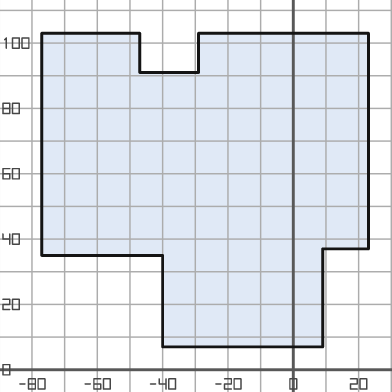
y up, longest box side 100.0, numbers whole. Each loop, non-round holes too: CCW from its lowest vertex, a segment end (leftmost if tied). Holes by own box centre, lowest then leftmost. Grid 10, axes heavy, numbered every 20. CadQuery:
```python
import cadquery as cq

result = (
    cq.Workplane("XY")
    .moveTo(-40.0, 7.0)
    .lineTo(9.0, 7.0)
    .lineTo(9.0, 37.0)
    .lineTo(23.0, 37.0)
    .lineTo(23.0, 103.0)
    .lineTo(-29.0, 103.0)
    .lineTo(-29.0, 91.0)
    .lineTo(-47.0, 91.0)
    .lineTo(-47.0, 103.0)
    .lineTo(-77.0, 103.0)
    .lineTo(-77.0, 35.0)
    .lineTo(-40.0, 35.0)
    .close()
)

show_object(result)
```